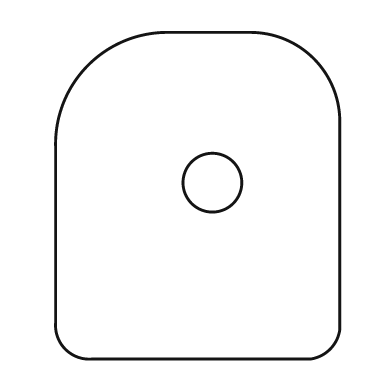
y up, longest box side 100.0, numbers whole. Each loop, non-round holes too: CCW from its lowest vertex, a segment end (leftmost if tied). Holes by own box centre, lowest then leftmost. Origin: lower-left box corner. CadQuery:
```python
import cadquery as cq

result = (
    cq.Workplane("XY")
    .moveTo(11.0, 0.0)
    .lineTo(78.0, 0.0)
    .threePointArc((84.0, 3.0), (87.0, 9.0))
    .lineTo(87.0, 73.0)
    .threePointArc((79.0, 92.0), (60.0, 100.0))
    .lineTo(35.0, 100.0)
    .threePointArc((10.0, 90.0), (0.0, 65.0))
    .lineTo(0.0, 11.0)
    .threePointArc((3.0, 3.0), (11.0, 0.0))
    .close()
    .moveTo(48.0, 54.0)
    .circle(9.0)
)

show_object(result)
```